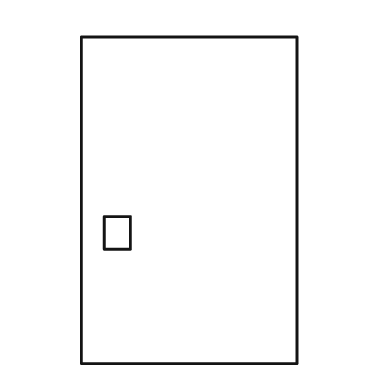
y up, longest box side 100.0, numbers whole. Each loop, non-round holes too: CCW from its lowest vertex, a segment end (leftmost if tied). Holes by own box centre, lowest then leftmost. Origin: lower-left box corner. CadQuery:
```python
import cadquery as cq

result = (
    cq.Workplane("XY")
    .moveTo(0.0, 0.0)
    .lineTo(66.0, 0.0)
    .lineTo(66.0, 100.0)
    .lineTo(0.0, 100.0)
    .close()
    .moveTo(7.0, 35.0)
    .lineTo(15.0, 35.0)
    .lineTo(15.0, 45.0)
    .lineTo(7.0, 45.0)
    .close()
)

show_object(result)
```